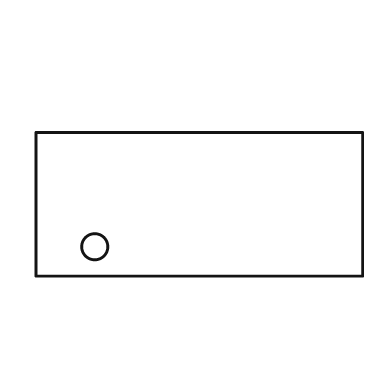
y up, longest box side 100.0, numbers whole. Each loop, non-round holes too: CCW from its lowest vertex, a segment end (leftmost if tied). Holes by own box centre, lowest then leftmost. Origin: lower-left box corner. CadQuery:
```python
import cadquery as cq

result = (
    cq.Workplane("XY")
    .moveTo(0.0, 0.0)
    .lineTo(100.0, 0.0)
    .lineTo(100.0, 44.0)
    .lineTo(0.0, 44.0)
    .close()
    .moveTo(18.0, 9.0)
    .circle(4.0)
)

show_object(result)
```